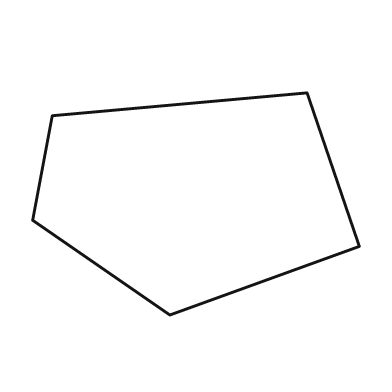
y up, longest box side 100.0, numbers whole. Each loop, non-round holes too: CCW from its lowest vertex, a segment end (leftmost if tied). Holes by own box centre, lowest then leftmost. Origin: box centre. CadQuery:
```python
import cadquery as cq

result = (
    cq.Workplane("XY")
    .moveTo(-8.0, -34.0)
    .lineTo(50.0, -13.0)
    .lineTo(34.0, 34.0)
    .lineTo(-44.0, 27.0)
    .lineTo(-50.0, -5.0)
    .close()
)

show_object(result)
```